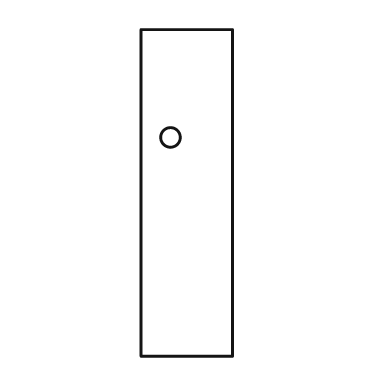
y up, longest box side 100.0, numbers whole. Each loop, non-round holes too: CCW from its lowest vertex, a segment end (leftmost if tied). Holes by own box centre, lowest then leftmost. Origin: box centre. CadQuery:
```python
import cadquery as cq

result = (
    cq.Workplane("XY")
    .moveTo(-14.0, -50.0)
    .lineTo(14.0, -50.0)
    .lineTo(14.0, 50.0)
    .lineTo(-14.0, 50.0)
    .close()
    .moveTo(-5.0, 17.0)
    .circle(3.0)
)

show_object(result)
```